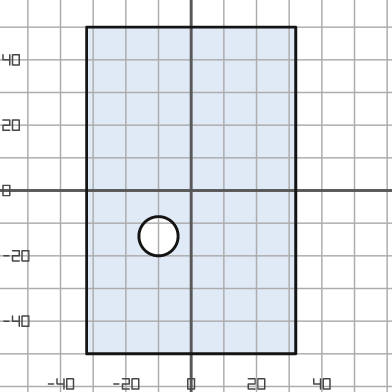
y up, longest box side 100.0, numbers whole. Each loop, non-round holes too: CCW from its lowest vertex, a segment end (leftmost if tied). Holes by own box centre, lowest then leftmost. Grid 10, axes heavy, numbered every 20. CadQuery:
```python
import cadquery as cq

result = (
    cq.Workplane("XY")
    .moveTo(-32.0, -50.0)
    .lineTo(32.0, -50.0)
    .lineTo(32.0, 50.0)
    .lineTo(-32.0, 50.0)
    .close()
    .moveTo(-10.0, -14.0)
    .circle(6.0)
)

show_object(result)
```